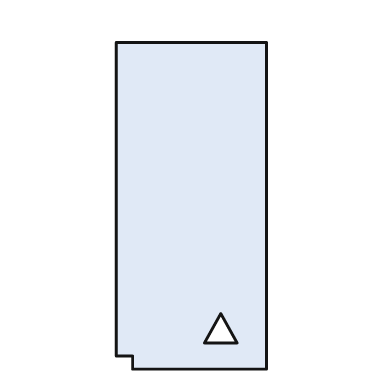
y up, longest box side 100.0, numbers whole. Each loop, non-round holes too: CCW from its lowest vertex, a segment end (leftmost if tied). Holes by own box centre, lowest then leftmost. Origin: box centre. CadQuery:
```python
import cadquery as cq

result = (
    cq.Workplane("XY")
    .moveTo(-18.0, -50.0)
    .lineTo(23.0, -50.0)
    .lineTo(23.0, 50.0)
    .lineTo(-23.0, 50.0)
    .lineTo(-23.0, -46.0)
    .lineTo(-18.0, -46.0)
    .close()
    .moveTo(4.0, -42.0)
    .lineTo(14.0, -42.0)
    .lineTo(9.0, -33.0)
    .close()
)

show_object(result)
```